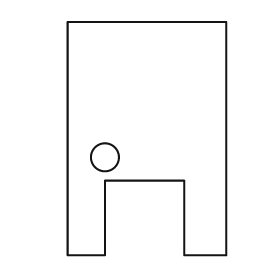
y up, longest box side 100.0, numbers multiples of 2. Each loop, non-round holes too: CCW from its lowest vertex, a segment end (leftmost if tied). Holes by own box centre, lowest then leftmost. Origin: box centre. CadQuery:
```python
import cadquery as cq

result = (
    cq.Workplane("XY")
    .moveTo(-34.0, -50.0)
    .lineTo(-18.0, -50.0)
    .lineTo(-18.0, -18.0)
    .lineTo(16.0, -18.0)
    .lineTo(16.0, -50.0)
    .lineTo(34.0, -50.0)
    .lineTo(34.0, 50.0)
    .lineTo(-34.0, 50.0)
    .close()
    .moveTo(-18.0, -8.0)
    .circle(6.0)
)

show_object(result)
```